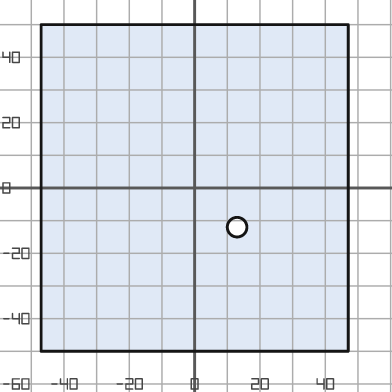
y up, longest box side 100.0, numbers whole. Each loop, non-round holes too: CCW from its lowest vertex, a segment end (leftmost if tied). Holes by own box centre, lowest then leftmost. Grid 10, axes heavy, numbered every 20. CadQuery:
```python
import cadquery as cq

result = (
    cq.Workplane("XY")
    .moveTo(-47.0, -50.0)
    .lineTo(47.0, -50.0)
    .lineTo(47.0, 50.0)
    .lineTo(-47.0, 50.0)
    .close()
    .moveTo(13.0, -12.0)
    .circle(3.0)
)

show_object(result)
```